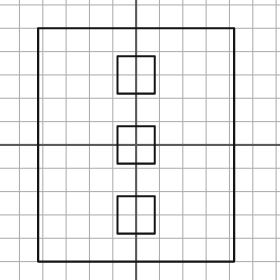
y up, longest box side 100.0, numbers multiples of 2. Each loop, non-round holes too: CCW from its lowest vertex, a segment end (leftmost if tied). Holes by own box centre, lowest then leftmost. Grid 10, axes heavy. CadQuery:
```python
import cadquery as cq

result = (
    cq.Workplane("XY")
    .moveTo(-42.0, -50.0)
    .lineTo(42.0, -50.0)
    .lineTo(42.0, 50.0)
    .lineTo(-42.0, 50.0)
    .close()
    .moveTo(-8.0, -38.0)
    .lineTo(8.0, -38.0)
    .lineTo(8.0, -22.0)
    .lineTo(-8.0, -22.0)
    .close()
    .moveTo(-8.0, -8.0)
    .lineTo(8.0, -8.0)
    .lineTo(8.0, 8.0)
    .lineTo(-8.0, 8.0)
    .close()
    .moveTo(-8.0, 22.0)
    .lineTo(8.0, 22.0)
    .lineTo(8.0, 38.0)
    .lineTo(-8.0, 38.0)
    .close()
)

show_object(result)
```